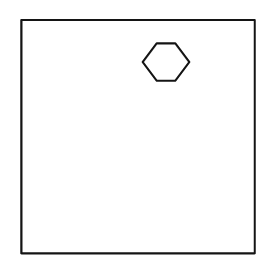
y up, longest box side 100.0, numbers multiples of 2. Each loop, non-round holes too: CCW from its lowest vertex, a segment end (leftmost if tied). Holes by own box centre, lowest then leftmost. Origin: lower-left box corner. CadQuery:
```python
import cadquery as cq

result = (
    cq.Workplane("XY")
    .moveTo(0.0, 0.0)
    .lineTo(100.0, 0.0)
    .lineTo(100.0, 100.0)
    .lineTo(0.0, 100.0)
    .close()
    .moveTo(58.0, 74.0)
    .lineTo(66.0, 74.0)
    .lineTo(72.0, 82.0)
    .lineTo(66.0, 90.0)
    .lineTo(58.0, 90.0)
    .lineTo(52.0, 82.0)
    .close()
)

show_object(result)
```